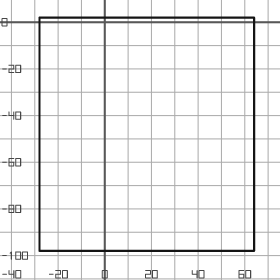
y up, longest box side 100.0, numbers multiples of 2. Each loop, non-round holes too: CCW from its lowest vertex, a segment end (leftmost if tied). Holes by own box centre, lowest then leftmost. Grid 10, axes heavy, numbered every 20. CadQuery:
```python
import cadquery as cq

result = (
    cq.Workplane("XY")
    .moveTo(-28.0, -98.0)
    .lineTo(64.0, -98.0)
    .lineTo(64.0, 2.0)
    .lineTo(-28.0, 2.0)
    .close()
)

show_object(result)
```